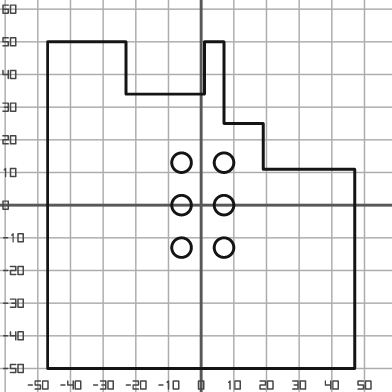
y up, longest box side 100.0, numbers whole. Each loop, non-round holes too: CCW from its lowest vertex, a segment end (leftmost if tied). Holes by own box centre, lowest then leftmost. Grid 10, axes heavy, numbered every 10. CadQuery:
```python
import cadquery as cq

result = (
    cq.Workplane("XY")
    .moveTo(-47.0, -50.0)
    .lineTo(47.0, -50.0)
    .lineTo(47.0, 11.0)
    .lineTo(19.0, 11.0)
    .lineTo(19.0, 25.0)
    .lineTo(7.0, 25.0)
    .lineTo(7.0, 50.0)
    .lineTo(1.0, 50.0)
    .lineTo(1.0, 34.0)
    .lineTo(-23.0, 34.0)
    .lineTo(-23.0, 50.0)
    .lineTo(-47.0, 50.0)
    .close()
    .moveTo(-6.0, -13.0)
    .circle(3.0)
    .moveTo(7.0, -13.0)
    .circle(3.0)
    .moveTo(-6.0, 0.0)
    .circle(3.0)
    .moveTo(7.0, 0.0)
    .circle(3.0)
    .moveTo(-6.0, 13.0)
    .circle(3.0)
    .moveTo(7.0, 13.0)
    .circle(3.0)
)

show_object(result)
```